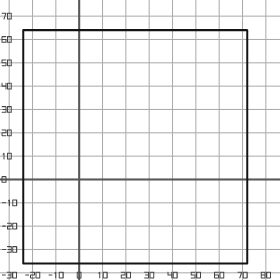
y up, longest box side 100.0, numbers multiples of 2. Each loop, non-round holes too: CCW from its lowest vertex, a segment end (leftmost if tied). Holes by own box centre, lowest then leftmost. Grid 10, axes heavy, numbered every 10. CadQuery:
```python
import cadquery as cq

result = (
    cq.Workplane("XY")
    .moveTo(-24.0, -36.0)
    .lineTo(72.0, -36.0)
    .lineTo(72.0, 64.0)
    .lineTo(-24.0, 64.0)
    .close()
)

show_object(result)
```